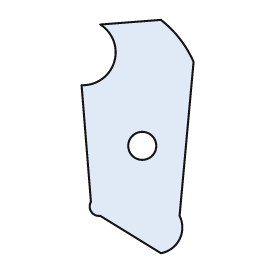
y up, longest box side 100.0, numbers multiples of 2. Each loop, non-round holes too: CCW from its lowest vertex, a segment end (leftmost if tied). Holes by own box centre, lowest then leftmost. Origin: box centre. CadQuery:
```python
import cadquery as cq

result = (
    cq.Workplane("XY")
    .moveTo(10.0, -50.0)
    .threePointArc((18.0, -44.0), (18.0, -34.0))
    .lineTo(24.0, 32.0)
    .threePointArc((18.0, 42.0), (10.0, 50.0))
    .lineTo(-16.0, 48.0)
    .threePointArc((-10.0, 32.0), (-24.0, 22.0))
    .lineTo(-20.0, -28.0)
    .threePointArc((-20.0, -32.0), (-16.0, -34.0))
    .close()
    .moveTo(2.0, -4.0)
    .circle(6.0)
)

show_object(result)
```